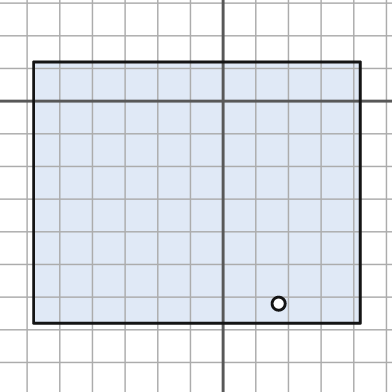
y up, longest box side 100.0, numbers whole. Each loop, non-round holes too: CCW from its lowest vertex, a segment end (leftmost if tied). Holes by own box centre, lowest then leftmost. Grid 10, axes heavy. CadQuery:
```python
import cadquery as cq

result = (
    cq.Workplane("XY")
    .moveTo(-58.0, -68.0)
    .lineTo(42.0, -68.0)
    .lineTo(42.0, 12.0)
    .lineTo(-58.0, 12.0)
    .close()
    .moveTo(17.0, -62.0)
    .circle(2.0)
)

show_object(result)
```